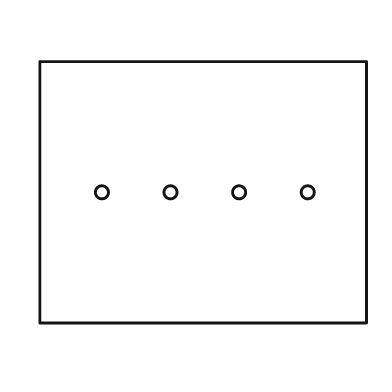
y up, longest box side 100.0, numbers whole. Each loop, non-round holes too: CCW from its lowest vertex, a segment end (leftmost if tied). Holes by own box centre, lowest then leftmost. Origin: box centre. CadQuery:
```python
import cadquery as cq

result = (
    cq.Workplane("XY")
    .moveTo(-50.0, -40.0)
    .lineTo(50.0, -40.0)
    .lineTo(50.0, 40.0)
    .lineTo(-50.0, 40.0)
    .close()
    .moveTo(-31.0, 0.0)
    .circle(2.0)
    .moveTo(-10.0, 0.0)
    .circle(2.0)
    .moveTo(11.0, 0.0)
    .circle(2.0)
    .moveTo(32.0, 0.0)
    .circle(2.0)
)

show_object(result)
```